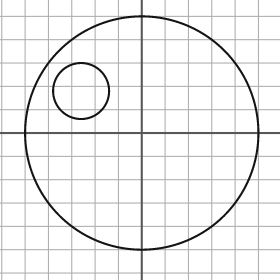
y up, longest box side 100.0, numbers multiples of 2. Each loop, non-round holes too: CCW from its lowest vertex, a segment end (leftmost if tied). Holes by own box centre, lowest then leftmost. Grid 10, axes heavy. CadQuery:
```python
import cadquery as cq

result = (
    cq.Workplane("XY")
    .moveTo(0.0, 0.0)
    .circle(50.0)
    .moveTo(-26.0, 18.0)
    .circle(12.0)
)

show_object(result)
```